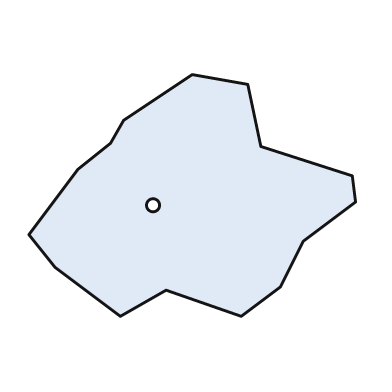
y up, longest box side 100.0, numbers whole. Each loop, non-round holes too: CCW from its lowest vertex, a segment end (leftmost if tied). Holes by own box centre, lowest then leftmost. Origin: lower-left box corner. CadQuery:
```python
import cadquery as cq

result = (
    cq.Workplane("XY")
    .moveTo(28.0, 0.0)
    .lineTo(42.0, 8.0)
    .lineTo(65.0, 0.0)
    .lineTo(77.0, 9.0)
    .lineTo(84.0, 23.0)
    .lineTo(100.0, 35.0)
    .lineTo(99.0, 43.0)
    .lineTo(71.0, 52.0)
    .lineTo(67.0, 71.0)
    .lineTo(50.0, 74.0)
    .lineTo(29.0, 60.0)
    .lineTo(25.0, 53.0)
    .lineTo(15.0, 45.0)
    .lineTo(0.0, 25.0)
    .lineTo(8.0, 15.0)
    .close()
    .moveTo(38.0, 34.0)
    .circle(2.0)
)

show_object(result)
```